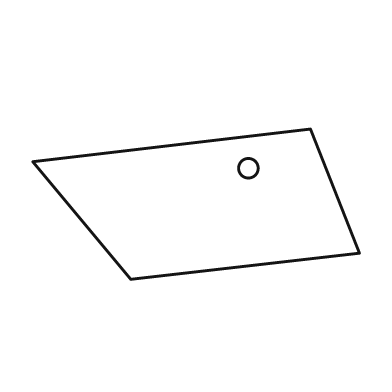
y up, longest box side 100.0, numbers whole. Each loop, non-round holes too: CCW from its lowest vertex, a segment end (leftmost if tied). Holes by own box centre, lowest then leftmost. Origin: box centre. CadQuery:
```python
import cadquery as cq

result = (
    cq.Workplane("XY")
    .moveTo(-20.0, -23.0)
    .lineTo(50.0, -15.0)
    .lineTo(35.0, 23.0)
    .lineTo(-50.0, 13.0)
    .close()
    .moveTo(16.0, 11.0)
    .circle(3.0)
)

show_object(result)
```